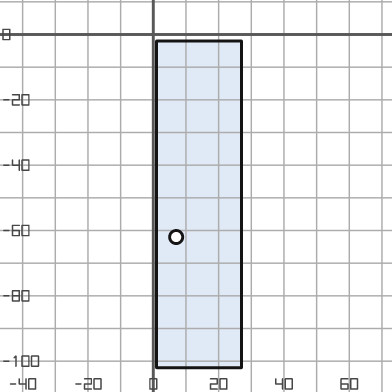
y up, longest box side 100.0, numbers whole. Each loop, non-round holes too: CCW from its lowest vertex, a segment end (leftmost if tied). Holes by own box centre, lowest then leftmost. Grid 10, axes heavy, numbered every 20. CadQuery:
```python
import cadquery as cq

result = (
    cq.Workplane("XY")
    .moveTo(1.0, -102.0)
    .lineTo(27.0, -102.0)
    .lineTo(27.0, -2.0)
    .lineTo(1.0, -2.0)
    .close()
    .moveTo(7.0, -62.0)
    .circle(2.0)
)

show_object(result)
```